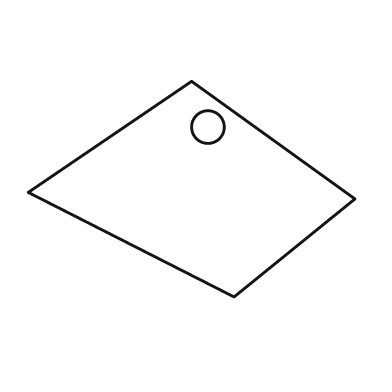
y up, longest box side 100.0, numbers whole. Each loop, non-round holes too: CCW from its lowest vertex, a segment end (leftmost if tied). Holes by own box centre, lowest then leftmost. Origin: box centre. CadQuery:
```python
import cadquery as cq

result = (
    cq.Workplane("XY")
    .moveTo(13.0, -33.0)
    .lineTo(50.0, -3.0)
    .lineTo(0.0, 33.0)
    .lineTo(-50.0, -1.0)
    .close()
    .moveTo(5.0, 19.0)
    .circle(5.0)
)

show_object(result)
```